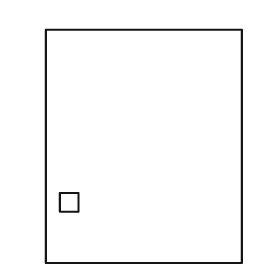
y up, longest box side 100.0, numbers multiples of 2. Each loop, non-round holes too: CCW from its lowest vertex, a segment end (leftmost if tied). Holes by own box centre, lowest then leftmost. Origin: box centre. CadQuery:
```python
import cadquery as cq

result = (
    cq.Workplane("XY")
    .moveTo(-42.0, -50.0)
    .lineTo(42.0, -50.0)
    .lineTo(42.0, 50.0)
    .lineTo(-42.0, 50.0)
    .close()
    .moveTo(-36.0, -28.0)
    .lineTo(-28.0, -28.0)
    .lineTo(-28.0, -20.0)
    .lineTo(-36.0, -20.0)
    .close()
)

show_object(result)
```